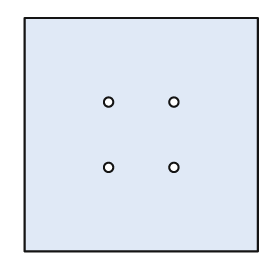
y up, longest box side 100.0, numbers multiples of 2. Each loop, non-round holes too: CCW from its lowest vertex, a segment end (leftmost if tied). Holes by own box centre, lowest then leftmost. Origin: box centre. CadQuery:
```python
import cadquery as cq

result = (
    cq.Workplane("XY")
    .moveTo(-50.0, -50.0)
    .lineTo(50.0, -50.0)
    .lineTo(50.0, 50.0)
    .lineTo(-50.0, 50.0)
    .close()
    .moveTo(-14.0, -14.0)
    .circle(2.0)
    .moveTo(14.0, -14.0)
    .circle(2.0)
    .moveTo(-14.0, 14.0)
    .circle(2.0)
    .moveTo(14.0, 14.0)
    .circle(2.0)
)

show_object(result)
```